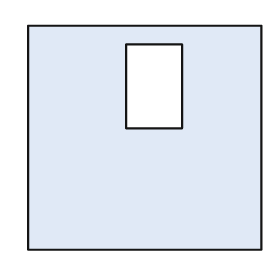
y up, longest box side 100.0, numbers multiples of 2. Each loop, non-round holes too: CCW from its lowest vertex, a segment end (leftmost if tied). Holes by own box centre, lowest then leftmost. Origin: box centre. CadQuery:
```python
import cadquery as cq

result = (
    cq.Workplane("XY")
    .moveTo(-50.0, -48.0)
    .lineTo(50.0, -48.0)
    .lineTo(50.0, 48.0)
    .lineTo(-50.0, 48.0)
    .close()
    .moveTo(-8.0, 4.0)
    .lineTo(16.0, 4.0)
    .lineTo(16.0, 40.0)
    .lineTo(-8.0, 40.0)
    .close()
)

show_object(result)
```